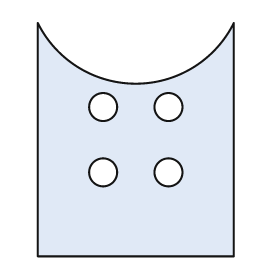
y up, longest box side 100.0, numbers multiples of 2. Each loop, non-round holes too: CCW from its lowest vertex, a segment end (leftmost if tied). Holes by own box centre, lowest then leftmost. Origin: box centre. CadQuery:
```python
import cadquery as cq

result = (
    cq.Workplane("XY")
    .moveTo(-42.0, -50.0)
    .lineTo(42.0, -50.0)
    .lineTo(42.0, 50.0)
    .threePointArc((0.0, 24.0), (-42.0, 50.0))
    .close()
    .moveTo(-14.0, -14.0)
    .circle(6.0)
    .moveTo(14.0, -14.0)
    .circle(6.0)
    .moveTo(-14.0, 14.0)
    .circle(6.0)
    .moveTo(14.0, 14.0)
    .circle(6.0)
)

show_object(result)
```